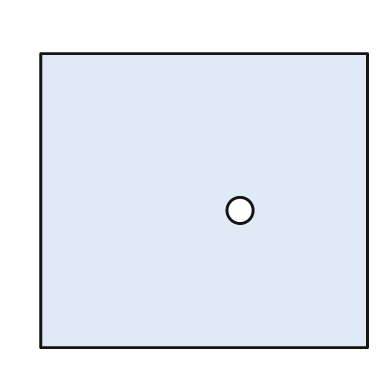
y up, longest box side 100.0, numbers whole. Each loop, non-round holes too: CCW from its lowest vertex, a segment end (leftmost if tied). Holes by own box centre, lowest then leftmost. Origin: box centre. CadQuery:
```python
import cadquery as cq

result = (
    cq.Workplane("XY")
    .moveTo(-50.0, -45.0)
    .lineTo(50.0, -45.0)
    .lineTo(50.0, 45.0)
    .lineTo(-50.0, 45.0)
    .close()
    .moveTo(11.0, -3.0)
    .circle(4.0)
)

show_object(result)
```